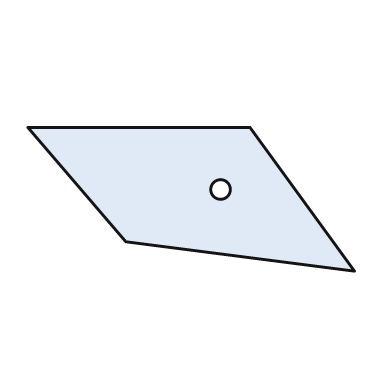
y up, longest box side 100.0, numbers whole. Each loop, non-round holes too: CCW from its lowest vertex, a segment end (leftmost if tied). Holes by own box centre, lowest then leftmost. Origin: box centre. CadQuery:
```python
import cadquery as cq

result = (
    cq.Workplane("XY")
    .moveTo(50.0, -22.0)
    .lineTo(18.0, 22.0)
    .lineTo(-50.0, 22.0)
    .lineTo(-20.0, -13.0)
    .close()
    .moveTo(9.0, 3.0)
    .circle(3.0)
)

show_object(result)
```